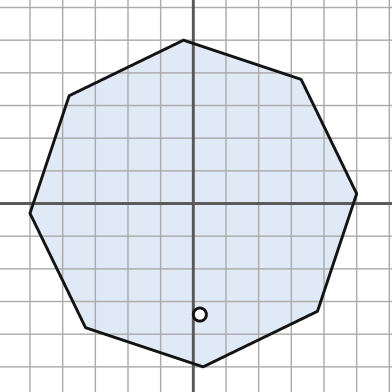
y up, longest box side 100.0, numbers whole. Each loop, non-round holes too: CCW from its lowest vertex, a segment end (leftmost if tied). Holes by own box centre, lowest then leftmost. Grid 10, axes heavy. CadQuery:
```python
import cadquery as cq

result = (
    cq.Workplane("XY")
    .moveTo(3.0, -50.0)
    .lineTo(38.0, -33.0)
    .lineTo(50.0, 3.0)
    .lineTo(33.0, 38.0)
    .lineTo(-3.0, 50.0)
    .lineTo(-38.0, 33.0)
    .lineTo(-50.0, -3.0)
    .lineTo(-33.0, -38.0)
    .close()
    .moveTo(2.0, -34.0)
    .circle(2.0)
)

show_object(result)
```